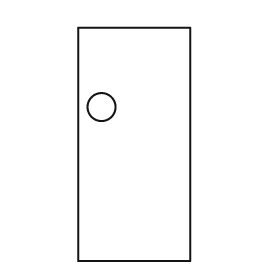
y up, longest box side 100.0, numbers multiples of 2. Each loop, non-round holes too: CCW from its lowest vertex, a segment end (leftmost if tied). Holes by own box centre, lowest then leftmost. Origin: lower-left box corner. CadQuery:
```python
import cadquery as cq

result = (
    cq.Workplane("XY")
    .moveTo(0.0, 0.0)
    .lineTo(48.0, 0.0)
    .lineTo(48.0, 100.0)
    .lineTo(0.0, 100.0)
    .close()
    .moveTo(10.0, 66.0)
    .circle(6.0)
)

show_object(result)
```